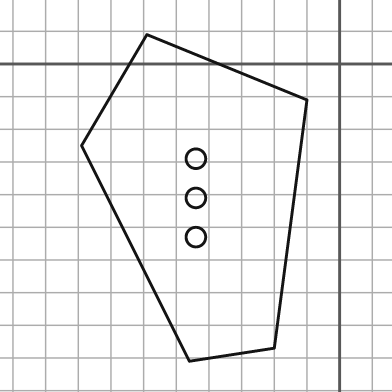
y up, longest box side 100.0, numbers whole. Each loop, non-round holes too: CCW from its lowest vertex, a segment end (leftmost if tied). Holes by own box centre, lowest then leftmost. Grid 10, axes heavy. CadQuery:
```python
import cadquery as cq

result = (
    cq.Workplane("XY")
    .moveTo(-46.0, -91.0)
    .lineTo(-20.0, -87.0)
    .lineTo(-10.0, -11.0)
    .lineTo(-59.0, 9.0)
    .lineTo(-79.0, -25.0)
    .close()
    .moveTo(-44.0, -53.0)
    .circle(3.0)
    .moveTo(-44.0, -41.0)
    .circle(3.0)
    .moveTo(-44.0, -29.0)
    .circle(3.0)
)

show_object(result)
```